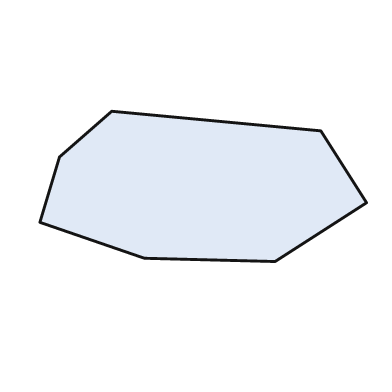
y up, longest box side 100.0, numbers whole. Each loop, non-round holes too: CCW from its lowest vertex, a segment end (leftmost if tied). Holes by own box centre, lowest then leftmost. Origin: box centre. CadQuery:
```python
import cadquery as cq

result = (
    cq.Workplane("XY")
    .moveTo(22.0, -23.0)
    .lineTo(50.0, -5.0)
    .lineTo(36.0, 17.0)
    .lineTo(-28.0, 23.0)
    .lineTo(-44.0, 9.0)
    .lineTo(-50.0, -11.0)
    .lineTo(-18.0, -22.0)
    .close()
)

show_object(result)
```